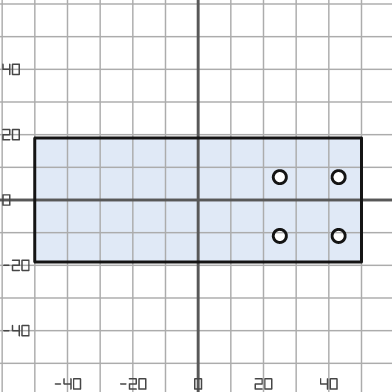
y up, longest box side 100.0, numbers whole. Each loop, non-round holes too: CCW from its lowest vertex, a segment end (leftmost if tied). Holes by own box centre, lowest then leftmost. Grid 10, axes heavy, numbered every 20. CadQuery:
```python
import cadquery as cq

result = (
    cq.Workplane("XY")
    .moveTo(-50.0, -19.0)
    .lineTo(50.0, -19.0)
    .lineTo(50.0, 19.0)
    .lineTo(-50.0, 19.0)
    .close()
    .moveTo(25.0, -11.0)
    .circle(2.0)
    .moveTo(43.0, -11.0)
    .circle(2.0)
    .moveTo(25.0, 7.0)
    .circle(2.0)
    .moveTo(43.0, 7.0)
    .circle(2.0)
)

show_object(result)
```